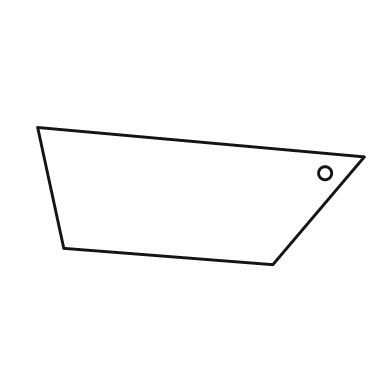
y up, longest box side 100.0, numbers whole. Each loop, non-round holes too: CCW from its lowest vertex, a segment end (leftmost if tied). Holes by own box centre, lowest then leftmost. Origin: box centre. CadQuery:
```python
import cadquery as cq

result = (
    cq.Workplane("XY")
    .moveTo(22.0, -21.0)
    .lineTo(50.0, 12.0)
    .lineTo(-50.0, 21.0)
    .lineTo(-42.0, -16.0)
    .close()
    .moveTo(38.0, 7.0)
    .circle(2.0)
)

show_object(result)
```